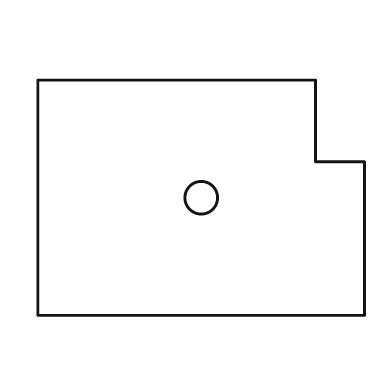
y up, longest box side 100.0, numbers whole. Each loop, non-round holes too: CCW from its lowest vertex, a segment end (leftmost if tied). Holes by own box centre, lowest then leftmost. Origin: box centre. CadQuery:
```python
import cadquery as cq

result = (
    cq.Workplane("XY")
    .moveTo(-50.0, -36.0)
    .lineTo(50.0, -36.0)
    .lineTo(50.0, 11.0)
    .lineTo(35.0, 11.0)
    .lineTo(35.0, 36.0)
    .lineTo(-50.0, 36.0)
    .close()
    .moveTo(0.0, 0.0)
    .circle(5.0)
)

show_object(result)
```